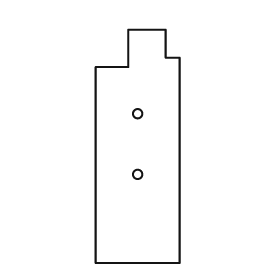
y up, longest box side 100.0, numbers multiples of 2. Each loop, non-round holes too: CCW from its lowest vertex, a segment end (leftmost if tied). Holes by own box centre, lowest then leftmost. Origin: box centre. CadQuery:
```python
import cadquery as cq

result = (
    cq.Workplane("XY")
    .moveTo(-18.0, -50.0)
    .lineTo(18.0, -50.0)
    .lineTo(18.0, 38.0)
    .lineTo(12.0, 38.0)
    .lineTo(12.0, 50.0)
    .lineTo(-4.0, 50.0)
    .lineTo(-4.0, 34.0)
    .lineTo(-18.0, 34.0)
    .close()
    .moveTo(0.0, -12.0)
    .circle(2.0)
    .moveTo(0.0, 14.0)
    .circle(2.0)
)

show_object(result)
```